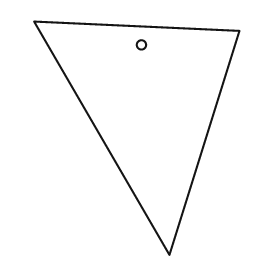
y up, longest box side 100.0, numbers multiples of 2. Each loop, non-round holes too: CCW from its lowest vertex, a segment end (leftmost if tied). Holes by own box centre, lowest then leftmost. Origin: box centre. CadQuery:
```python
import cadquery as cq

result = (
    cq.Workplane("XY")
    .moveTo(14.0, -50.0)
    .lineTo(44.0, 46.0)
    .lineTo(-44.0, 50.0)
    .close()
    .moveTo(2.0, 40.0)
    .circle(2.0)
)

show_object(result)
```